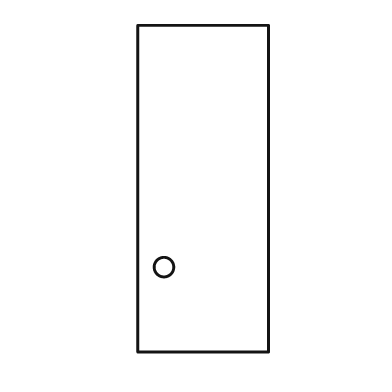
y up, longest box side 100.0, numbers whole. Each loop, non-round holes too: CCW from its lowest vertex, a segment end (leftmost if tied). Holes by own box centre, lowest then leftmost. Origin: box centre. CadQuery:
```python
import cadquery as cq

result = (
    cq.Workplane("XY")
    .moveTo(-20.0, -50.0)
    .lineTo(20.0, -50.0)
    .lineTo(20.0, 50.0)
    .lineTo(-20.0, 50.0)
    .close()
    .moveTo(-12.0, -24.0)
    .circle(3.0)
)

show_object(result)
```